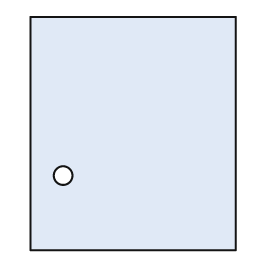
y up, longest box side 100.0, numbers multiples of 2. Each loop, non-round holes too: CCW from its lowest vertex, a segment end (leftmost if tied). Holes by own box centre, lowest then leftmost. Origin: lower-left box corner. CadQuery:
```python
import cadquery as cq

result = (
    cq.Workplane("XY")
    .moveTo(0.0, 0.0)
    .lineTo(88.0, 0.0)
    .lineTo(88.0, 100.0)
    .lineTo(0.0, 100.0)
    .close()
    .moveTo(14.0, 32.0)
    .circle(4.0)
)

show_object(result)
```